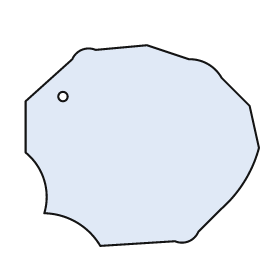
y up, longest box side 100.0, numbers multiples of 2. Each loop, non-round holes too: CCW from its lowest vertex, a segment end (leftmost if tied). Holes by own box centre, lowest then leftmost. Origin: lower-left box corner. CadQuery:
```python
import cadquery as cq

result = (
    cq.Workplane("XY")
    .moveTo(32.0, 0.0)
    .lineTo(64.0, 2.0)
    .threePointArc((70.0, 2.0), (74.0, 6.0))
    .lineTo(84.0, 16.0)
    .threePointArc((94.0, 28.0), (100.0, 42.0))
    .lineTo(96.0, 60.0)
    .lineTo(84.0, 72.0)
    .threePointArc((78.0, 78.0), (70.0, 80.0))
    .lineTo(52.0, 86.0)
    .lineTo(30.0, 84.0)
    .threePointArc((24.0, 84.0), (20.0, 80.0))
    .lineTo(0.0, 62.0)
    .lineTo(0.0, 40.0)
    .threePointArc((8.0, 28.0), (8.0, 14.0))
    .threePointArc((22.0, 10.0), (32.0, 0.0))
    .close()
    .moveTo(16.0, 64.0)
    .circle(2.0)
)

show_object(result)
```